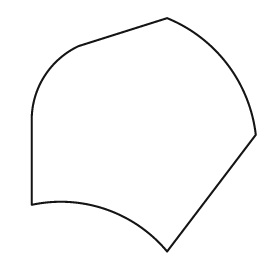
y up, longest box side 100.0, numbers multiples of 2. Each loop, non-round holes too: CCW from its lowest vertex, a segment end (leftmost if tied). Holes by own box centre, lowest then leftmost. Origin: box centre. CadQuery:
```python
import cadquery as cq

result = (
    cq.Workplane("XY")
    .moveTo(10.0, -50.0)
    .lineTo(48.0, 0.0)
    .threePointArc((36.0, 30.0), (10.0, 50.0))
    .lineTo(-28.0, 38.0)
    .threePointArc((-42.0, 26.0), (-48.0, 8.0))
    .lineTo(-48.0, -30.0)
    .threePointArc((-16.0, -32.0), (10.0, -50.0))
    .close()
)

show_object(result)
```